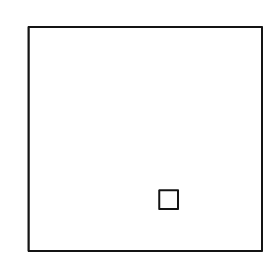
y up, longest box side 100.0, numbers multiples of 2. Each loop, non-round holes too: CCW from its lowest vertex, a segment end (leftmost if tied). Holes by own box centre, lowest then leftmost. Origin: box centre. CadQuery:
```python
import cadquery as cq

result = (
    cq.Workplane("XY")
    .moveTo(-50.0, -48.0)
    .lineTo(50.0, -48.0)
    .lineTo(50.0, 48.0)
    .lineTo(-50.0, 48.0)
    .close()
    .moveTo(6.0, -30.0)
    .lineTo(14.0, -30.0)
    .lineTo(14.0, -22.0)
    .lineTo(6.0, -22.0)
    .close()
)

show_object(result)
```